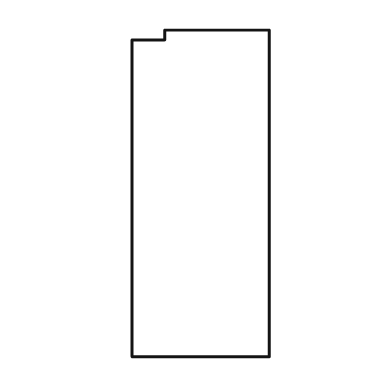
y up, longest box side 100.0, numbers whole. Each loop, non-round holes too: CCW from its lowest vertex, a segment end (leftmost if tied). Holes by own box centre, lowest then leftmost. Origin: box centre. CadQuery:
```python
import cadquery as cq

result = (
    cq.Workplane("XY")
    .moveTo(-21.0, -50.0)
    .lineTo(21.0, -50.0)
    .lineTo(21.0, 50.0)
    .lineTo(-11.0, 50.0)
    .lineTo(-11.0, 47.0)
    .lineTo(-21.0, 47.0)
    .close()
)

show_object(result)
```